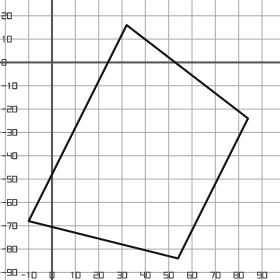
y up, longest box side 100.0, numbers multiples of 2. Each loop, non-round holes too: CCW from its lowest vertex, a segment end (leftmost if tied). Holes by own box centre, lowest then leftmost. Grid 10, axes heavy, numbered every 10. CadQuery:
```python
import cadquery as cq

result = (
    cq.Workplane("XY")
    .moveTo(54.0, -84.0)
    .lineTo(84.0, -24.0)
    .lineTo(32.0, 16.0)
    .lineTo(-10.0, -68.0)
    .close()
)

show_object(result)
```